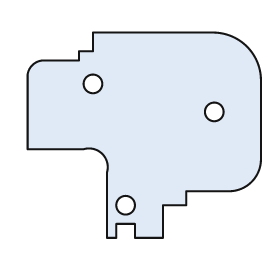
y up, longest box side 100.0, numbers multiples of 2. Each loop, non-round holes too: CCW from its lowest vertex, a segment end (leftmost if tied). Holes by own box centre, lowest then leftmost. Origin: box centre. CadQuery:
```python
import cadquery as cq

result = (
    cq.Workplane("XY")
    .moveTo(-16.0, -44.0)
    .lineTo(-12.0, -44.0)
    .lineTo(-12.0, -38.0)
    .lineTo(-4.0, -38.0)
    .lineTo(-4.0, -44.0)
    .lineTo(8.0, -44.0)
    .lineTo(8.0, -30.0)
    .lineTo(18.0, -30.0)
    .lineTo(18.0, -24.0)
    .lineTo(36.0, -24.0)
    .threePointArc((46.0, -20.0), (50.0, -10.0))
    .lineTo(50.0, 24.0)
    .threePointArc((44.0, 38.0), (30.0, 44.0))
    .lineTo(-22.0, 44.0)
    .lineTo(-22.0, 36.0)
    .lineTo(-28.0, 36.0)
    .lineTo(-28.0, 32.0)
    .lineTo(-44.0, 32.0)
    .threePointArc((-48.0, 30.0), (-50.0, 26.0))
    .lineTo(-50.0, -6.0)
    .lineTo(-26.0, -6.0)
    .threePointArc((-18.0, -8.0), (-16.0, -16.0))
    .close()
    .moveTo(-8.0, -30.0)
    .circle(4.0)
    .moveTo(30.0, 10.0)
    .circle(4.0)
    .moveTo(-22.0, 22.0)
    .circle(4.0)
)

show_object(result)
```